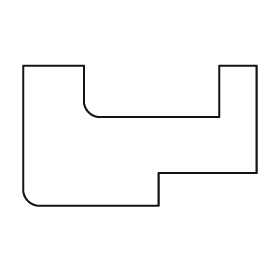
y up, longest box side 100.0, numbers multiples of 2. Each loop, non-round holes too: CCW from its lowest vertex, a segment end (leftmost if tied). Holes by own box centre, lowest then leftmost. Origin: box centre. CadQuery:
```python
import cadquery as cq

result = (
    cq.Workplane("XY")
    .moveTo(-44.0, -30.0)
    .lineTo(8.0, -30.0)
    .lineTo(8.0, -16.0)
    .lineTo(50.0, -16.0)
    .lineTo(50.0, 30.0)
    .lineTo(34.0, 30.0)
    .lineTo(34.0, 8.0)
    .lineTo(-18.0, 8.0)
    .threePointArc((-22.0, 10.0), (-24.0, 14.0))
    .lineTo(-24.0, 30.0)
    .lineTo(-50.0, 30.0)
    .lineTo(-50.0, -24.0)
    .threePointArc((-48.0, -28.0), (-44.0, -30.0))
    .close()
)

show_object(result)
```